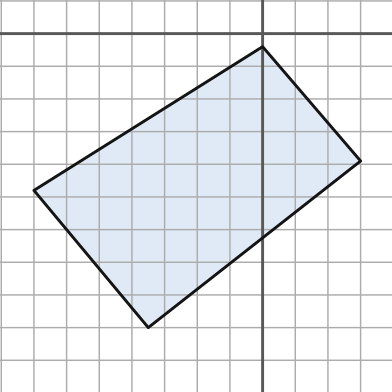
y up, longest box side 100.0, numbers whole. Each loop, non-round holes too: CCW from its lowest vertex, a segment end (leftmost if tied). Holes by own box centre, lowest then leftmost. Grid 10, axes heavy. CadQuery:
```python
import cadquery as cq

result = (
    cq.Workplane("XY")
    .moveTo(-35.0, -90.0)
    .lineTo(30.0, -39.0)
    .lineTo(0.0, -4.0)
    .lineTo(-70.0, -48.0)
    .close()
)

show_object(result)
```